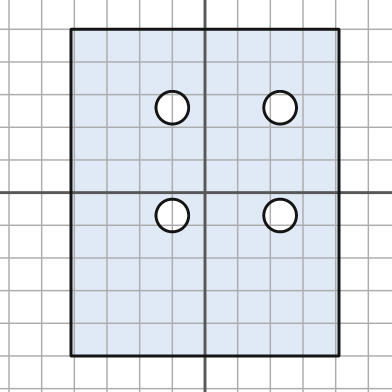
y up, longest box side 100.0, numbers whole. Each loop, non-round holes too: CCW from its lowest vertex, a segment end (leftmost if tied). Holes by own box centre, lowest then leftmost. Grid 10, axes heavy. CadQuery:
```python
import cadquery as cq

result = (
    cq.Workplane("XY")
    .moveTo(-41.0, -50.0)
    .lineTo(41.0, -50.0)
    .lineTo(41.0, 50.0)
    .lineTo(-41.0, 50.0)
    .close()
    .moveTo(-10.0, -7.0)
    .circle(5.0)
    .moveTo(23.0, -7.0)
    .circle(5.0)
    .moveTo(-10.0, 26.0)
    .circle(5.0)
    .moveTo(23.0, 26.0)
    .circle(5.0)
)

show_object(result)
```